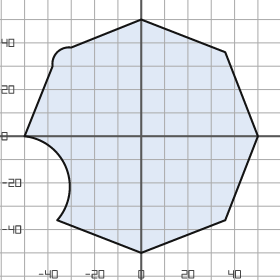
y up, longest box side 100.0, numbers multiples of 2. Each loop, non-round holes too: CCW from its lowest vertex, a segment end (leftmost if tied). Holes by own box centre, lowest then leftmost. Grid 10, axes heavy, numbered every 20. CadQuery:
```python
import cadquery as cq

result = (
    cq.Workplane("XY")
    .moveTo(0.0, -50.0)
    .lineTo(36.0, -36.0)
    .lineTo(50.0, 0.0)
    .lineTo(36.0, 36.0)
    .lineTo(0.0, 50.0)
    .lineTo(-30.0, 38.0)
    .threePointArc((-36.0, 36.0), (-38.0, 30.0))
    .lineTo(-50.0, 0.0)
    .threePointArc((-32.0, -14.0), (-36.0, -36.0))
    .close()
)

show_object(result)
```